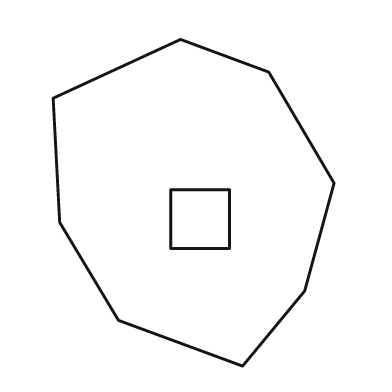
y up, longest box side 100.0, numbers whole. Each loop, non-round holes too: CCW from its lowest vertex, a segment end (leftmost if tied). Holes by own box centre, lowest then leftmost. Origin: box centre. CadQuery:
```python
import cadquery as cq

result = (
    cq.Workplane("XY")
    .moveTo(15.0, -50.0)
    .lineTo(34.0, -27.0)
    .lineTo(43.0, 6.0)
    .lineTo(23.0, 40.0)
    .lineTo(-4.0, 50.0)
    .lineTo(-43.0, 32.0)
    .lineTo(-41.0, -6.0)
    .lineTo(-23.0, -36.0)
    .close()
    .moveTo(-7.0, -14.0)
    .lineTo(11.0, -14.0)
    .lineTo(11.0, 4.0)
    .lineTo(-7.0, 4.0)
    .close()
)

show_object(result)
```